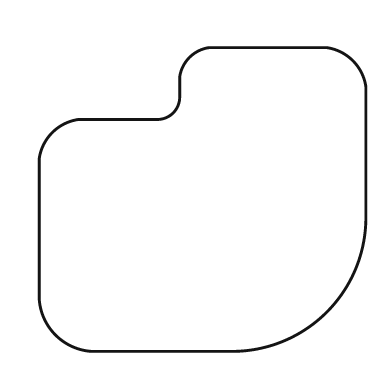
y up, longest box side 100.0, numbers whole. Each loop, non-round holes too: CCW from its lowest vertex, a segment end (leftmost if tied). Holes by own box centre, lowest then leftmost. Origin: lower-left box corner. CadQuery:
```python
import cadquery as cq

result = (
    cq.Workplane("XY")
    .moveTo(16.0, 0.0)
    .lineTo(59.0, 0.0)
    .threePointArc((88.0, 12.0), (100.0, 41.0))
    .lineTo(100.0, 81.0)
    .threePointArc((96.0, 89.0), (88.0, 93.0))
    .lineTo(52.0, 93.0)
    .threePointArc((46.0, 90.0), (43.0, 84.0))
    .lineTo(43.0, 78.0)
    .threePointArc((41.0, 73.0), (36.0, 71.0))
    .lineTo(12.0, 71.0)
    .threePointArc((4.0, 67.0), (0.0, 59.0))
    .lineTo(0.0, 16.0)
    .threePointArc((5.0, 5.0), (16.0, 0.0))
    .close()
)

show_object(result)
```